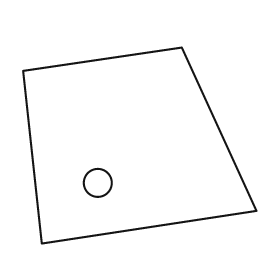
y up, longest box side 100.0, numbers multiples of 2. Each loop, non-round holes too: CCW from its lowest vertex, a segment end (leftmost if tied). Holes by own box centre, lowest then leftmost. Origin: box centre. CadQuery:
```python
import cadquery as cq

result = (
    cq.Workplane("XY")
    .moveTo(-42.0, -42.0)
    .lineTo(50.0, -28.0)
    .lineTo(18.0, 42.0)
    .lineTo(-50.0, 32.0)
    .close()
    .moveTo(-18.0, -16.0)
    .circle(6.0)
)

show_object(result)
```